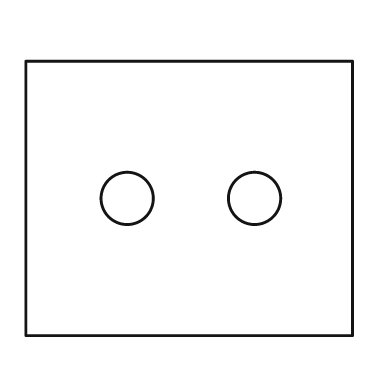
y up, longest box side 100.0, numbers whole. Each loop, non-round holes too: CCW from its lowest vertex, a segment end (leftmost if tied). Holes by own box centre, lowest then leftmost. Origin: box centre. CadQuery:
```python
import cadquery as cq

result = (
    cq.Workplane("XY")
    .moveTo(-50.0, -42.0)
    .lineTo(50.0, -42.0)
    .lineTo(50.0, 42.0)
    .lineTo(-50.0, 42.0)
    .close()
    .moveTo(-19.0, 0.0)
    .circle(8.0)
    .moveTo(20.0, 0.0)
    .circle(8.0)
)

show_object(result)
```